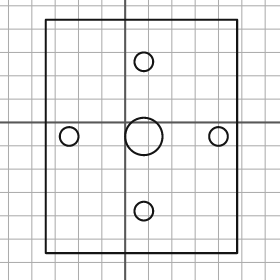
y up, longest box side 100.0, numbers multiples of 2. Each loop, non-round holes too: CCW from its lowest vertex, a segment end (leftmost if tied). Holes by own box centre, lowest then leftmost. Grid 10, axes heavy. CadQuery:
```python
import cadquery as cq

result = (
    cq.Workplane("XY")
    .moveTo(-34.0, -56.0)
    .lineTo(48.0, -56.0)
    .lineTo(48.0, 44.0)
    .lineTo(-34.0, 44.0)
    .close()
    .moveTo(8.0, -38.0)
    .circle(4.0)
    .moveTo(-24.0, -6.0)
    .circle(4.0)
    .moveTo(8.0, -6.0)
    .circle(8.0)
    .moveTo(40.0, -6.0)
    .circle(4.0)
    .moveTo(8.0, 26.0)
    .circle(4.0)
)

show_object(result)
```